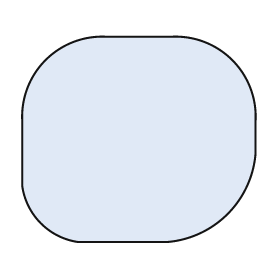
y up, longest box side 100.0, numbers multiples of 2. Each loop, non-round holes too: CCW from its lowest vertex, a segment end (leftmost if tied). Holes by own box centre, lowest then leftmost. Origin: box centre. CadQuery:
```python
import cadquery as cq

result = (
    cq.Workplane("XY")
    .moveTo(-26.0, -44.0)
    .lineTo(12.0, -44.0)
    .threePointArc((38.0, -32.0), (50.0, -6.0))
    .lineTo(50.0, 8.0)
    .threePointArc((40.0, 34.0), (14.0, 44.0))
    .lineTo(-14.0, 44.0)
    .threePointArc((-40.0, 34.0), (-50.0, 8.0))
    .lineTo(-50.0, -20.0)
    .threePointArc((-42.0, -36.0), (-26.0, -44.0))
    .close()
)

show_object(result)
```